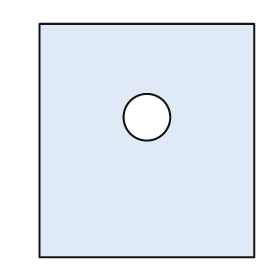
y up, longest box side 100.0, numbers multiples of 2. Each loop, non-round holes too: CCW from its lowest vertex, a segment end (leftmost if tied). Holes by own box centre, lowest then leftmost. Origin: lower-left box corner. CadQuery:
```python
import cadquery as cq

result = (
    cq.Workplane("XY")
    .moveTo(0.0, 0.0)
    .lineTo(92.0, 0.0)
    .lineTo(92.0, 100.0)
    .lineTo(0.0, 100.0)
    .close()
    .moveTo(46.0, 60.0)
    .circle(10.0)
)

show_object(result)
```